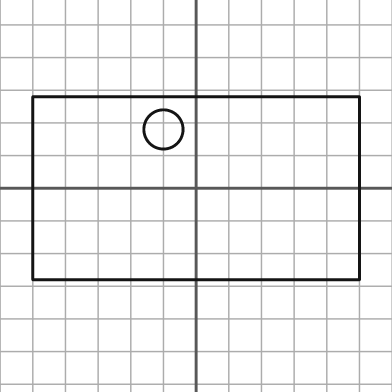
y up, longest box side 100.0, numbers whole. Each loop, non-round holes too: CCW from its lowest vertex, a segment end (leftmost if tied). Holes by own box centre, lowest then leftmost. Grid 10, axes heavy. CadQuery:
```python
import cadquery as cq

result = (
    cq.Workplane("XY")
    .moveTo(-50.0, -28.0)
    .lineTo(50.0, -28.0)
    .lineTo(50.0, 28.0)
    .lineTo(-50.0, 28.0)
    .close()
    .moveTo(-10.0, 18.0)
    .circle(6.0)
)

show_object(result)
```